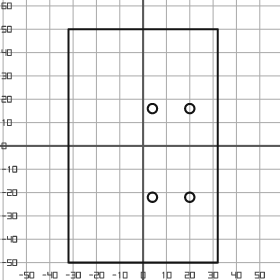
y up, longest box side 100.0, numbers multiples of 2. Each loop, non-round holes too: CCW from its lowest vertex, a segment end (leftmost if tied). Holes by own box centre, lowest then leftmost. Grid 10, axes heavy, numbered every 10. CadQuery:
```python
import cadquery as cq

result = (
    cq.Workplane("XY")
    .moveTo(-32.0, -50.0)
    .lineTo(32.0, -50.0)
    .lineTo(32.0, 50.0)
    .lineTo(-32.0, 50.0)
    .close()
    .moveTo(4.0, -22.0)
    .circle(2.0)
    .moveTo(20.0, -22.0)
    .circle(2.0)
    .moveTo(4.0, 16.0)
    .circle(2.0)
    .moveTo(20.0, 16.0)
    .circle(2.0)
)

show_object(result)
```